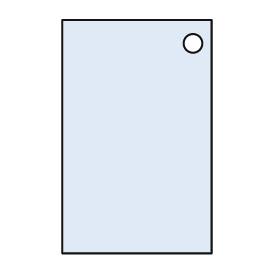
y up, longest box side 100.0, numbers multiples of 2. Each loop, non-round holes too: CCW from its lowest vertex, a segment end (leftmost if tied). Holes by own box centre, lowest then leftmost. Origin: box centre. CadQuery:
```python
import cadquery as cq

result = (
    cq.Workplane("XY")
    .moveTo(-32.0, -50.0)
    .lineTo(32.0, -50.0)
    .lineTo(32.0, 50.0)
    .lineTo(-32.0, 50.0)
    .close()
    .moveTo(24.0, 40.0)
    .circle(4.0)
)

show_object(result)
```